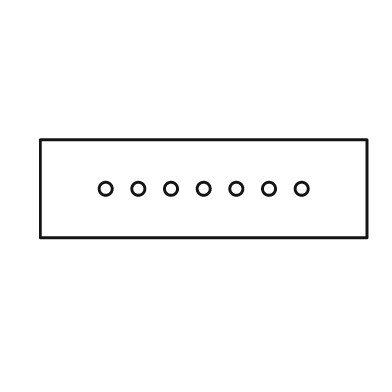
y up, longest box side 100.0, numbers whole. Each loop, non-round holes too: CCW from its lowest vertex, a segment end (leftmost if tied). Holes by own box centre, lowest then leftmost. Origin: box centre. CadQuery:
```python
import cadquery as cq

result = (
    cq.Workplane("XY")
    .moveTo(-50.0, -15.0)
    .lineTo(50.0, -15.0)
    .lineTo(50.0, 15.0)
    .lineTo(-50.0, 15.0)
    .close()
    .moveTo(-30.0, 0.0)
    .circle(2.0)
    .moveTo(-20.0, 0.0)
    .circle(2.0)
    .moveTo(-10.0, 0.0)
    .circle(2.0)
    .moveTo(0.0, 0.0)
    .circle(2.0)
    .moveTo(10.0, 0.0)
    .circle(2.0)
    .moveTo(20.0, 0.0)
    .circle(2.0)
    .moveTo(30.0, 0.0)
    .circle(2.0)
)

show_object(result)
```